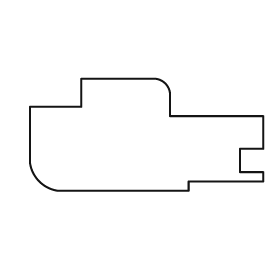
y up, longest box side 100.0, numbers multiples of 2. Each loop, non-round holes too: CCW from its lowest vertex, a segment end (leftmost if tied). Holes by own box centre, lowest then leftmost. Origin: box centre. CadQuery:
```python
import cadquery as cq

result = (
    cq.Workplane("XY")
    .moveTo(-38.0, -24.0)
    .lineTo(18.0, -24.0)
    .lineTo(18.0, -20.0)
    .lineTo(50.0, -20.0)
    .lineTo(50.0, -16.0)
    .lineTo(40.0, -16.0)
    .lineTo(40.0, -6.0)
    .lineTo(50.0, -6.0)
    .lineTo(50.0, 8.0)
    .lineTo(10.0, 8.0)
    .lineTo(10.0, 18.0)
    .threePointArc((8.0, 22.0), (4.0, 24.0))
    .lineTo(-28.0, 24.0)
    .lineTo(-28.0, 12.0)
    .lineTo(-50.0, 12.0)
    .lineTo(-50.0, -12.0)
    .threePointArc((-46.0, -20.0), (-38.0, -24.0))
    .close()
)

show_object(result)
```